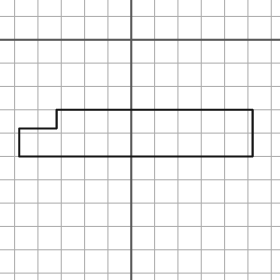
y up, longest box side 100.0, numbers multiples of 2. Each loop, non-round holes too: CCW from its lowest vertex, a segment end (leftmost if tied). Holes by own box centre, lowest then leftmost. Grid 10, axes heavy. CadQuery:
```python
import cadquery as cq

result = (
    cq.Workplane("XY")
    .moveTo(-48.0, -50.0)
    .lineTo(52.0, -50.0)
    .lineTo(52.0, -30.0)
    .lineTo(-32.0, -30.0)
    .lineTo(-32.0, -38.0)
    .lineTo(-48.0, -38.0)
    .close()
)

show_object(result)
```